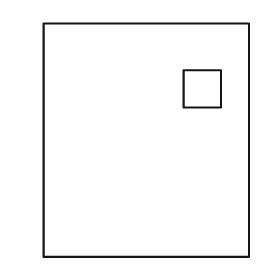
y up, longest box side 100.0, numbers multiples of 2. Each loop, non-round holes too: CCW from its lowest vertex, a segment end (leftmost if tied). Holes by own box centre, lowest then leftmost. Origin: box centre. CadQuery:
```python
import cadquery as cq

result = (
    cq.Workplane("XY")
    .moveTo(-44.0, -50.0)
    .lineTo(44.0, -50.0)
    .lineTo(44.0, 50.0)
    .lineTo(-44.0, 50.0)
    .close()
    .moveTo(16.0, 14.0)
    .lineTo(32.0, 14.0)
    .lineTo(32.0, 30.0)
    .lineTo(16.0, 30.0)
    .close()
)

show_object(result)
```